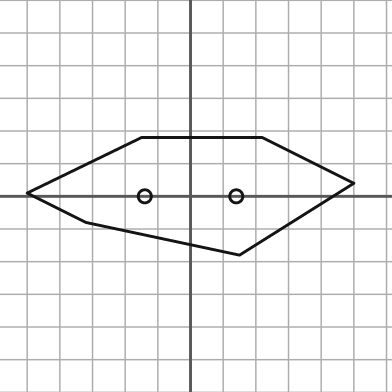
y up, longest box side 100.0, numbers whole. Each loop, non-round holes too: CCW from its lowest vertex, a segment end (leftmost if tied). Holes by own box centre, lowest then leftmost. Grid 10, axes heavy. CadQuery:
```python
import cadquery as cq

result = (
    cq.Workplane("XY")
    .moveTo(15.0, -18.0)
    .lineTo(50.0, 4.0)
    .lineTo(22.0, 18.0)
    .lineTo(-15.0, 18.0)
    .lineTo(-50.0, 1.0)
    .lineTo(-32.0, -8.0)
    .close()
    .moveTo(-14.0, 0.0)
    .circle(2.0)
    .moveTo(14.0, 0.0)
    .circle(2.0)
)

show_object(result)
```